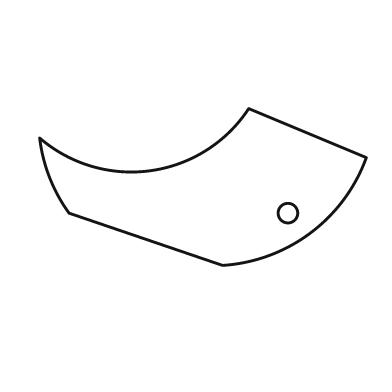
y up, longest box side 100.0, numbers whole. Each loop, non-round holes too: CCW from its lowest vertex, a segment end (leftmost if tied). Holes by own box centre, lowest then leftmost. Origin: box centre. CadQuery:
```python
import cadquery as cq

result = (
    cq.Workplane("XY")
    .moveTo(6.0, -24.0)
    .threePointArc((33.0, -14.0), (50.0, 9.0))
    .lineTo(14.0, 24.0)
    .threePointArc((-16.0, 5.0), (-50.0, 15.0))
    .threePointArc((-47.0, 3.0), (-41.0, -8.0))
    .close()
    .moveTo(26.0, -8.0)
    .circle(3.0)
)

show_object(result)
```